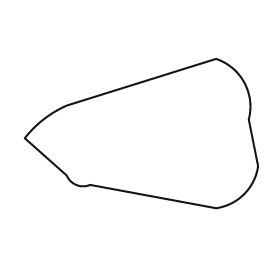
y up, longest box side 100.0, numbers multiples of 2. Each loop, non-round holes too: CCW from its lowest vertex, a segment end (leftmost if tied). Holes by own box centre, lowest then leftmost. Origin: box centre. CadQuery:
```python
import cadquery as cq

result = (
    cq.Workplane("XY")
    .moveTo(32.0, -32.0)
    .threePointArc((44.0, -26.0), (50.0, -14.0))
    .lineTo(46.0, 6.0)
    .threePointArc((44.0, 22.0), (32.0, 32.0))
    .lineTo(-32.0, 12.0)
    .threePointArc((-42.0, 6.0), (-50.0, -2.0))
    .lineTo(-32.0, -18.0)
    .threePointArc((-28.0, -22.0), (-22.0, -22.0))
    .close()
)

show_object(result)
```